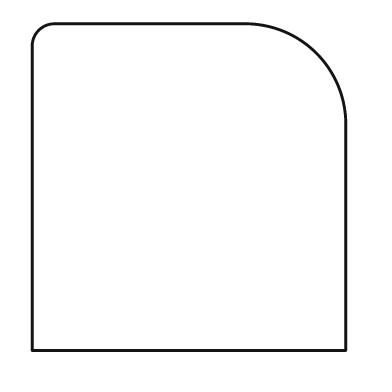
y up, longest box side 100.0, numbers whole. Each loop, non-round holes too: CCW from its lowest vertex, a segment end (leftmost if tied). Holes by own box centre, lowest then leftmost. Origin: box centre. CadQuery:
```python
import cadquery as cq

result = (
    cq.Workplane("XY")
    .moveTo(-48.0, -50.0)
    .lineTo(48.0, -50.0)
    .lineTo(48.0, 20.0)
    .threePointArc((39.0, 41.0), (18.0, 50.0))
    .lineTo(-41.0, 50.0)
    .threePointArc((-46.0, 48.0), (-48.0, 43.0))
    .close()
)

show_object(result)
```